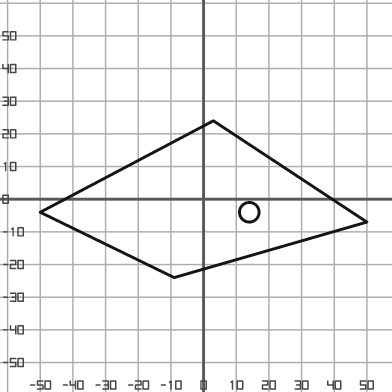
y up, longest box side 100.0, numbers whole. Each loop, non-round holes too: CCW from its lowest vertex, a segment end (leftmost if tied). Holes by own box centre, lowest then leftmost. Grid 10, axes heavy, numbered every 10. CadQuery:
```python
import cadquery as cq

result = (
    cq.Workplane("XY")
    .moveTo(-9.0, -24.0)
    .lineTo(50.0, -7.0)
    .lineTo(3.0, 24.0)
    .lineTo(-50.0, -4.0)
    .close()
    .moveTo(14.0, -4.0)
    .circle(3.0)
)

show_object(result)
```